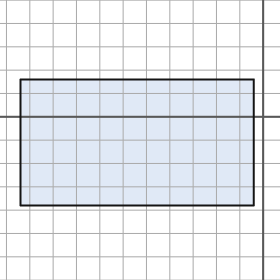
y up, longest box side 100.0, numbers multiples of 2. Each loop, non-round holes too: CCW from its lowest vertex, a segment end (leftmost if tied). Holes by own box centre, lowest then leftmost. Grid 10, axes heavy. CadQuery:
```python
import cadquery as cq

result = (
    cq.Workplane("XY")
    .moveTo(-104.0, -38.0)
    .lineTo(-4.0, -38.0)
    .lineTo(-4.0, 16.0)
    .lineTo(-104.0, 16.0)
    .close()
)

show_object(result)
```